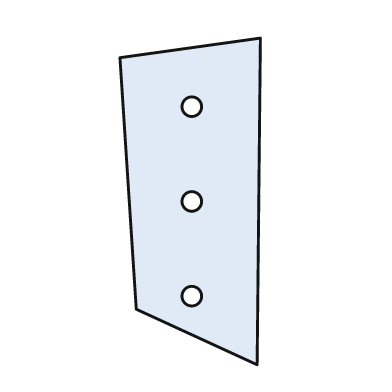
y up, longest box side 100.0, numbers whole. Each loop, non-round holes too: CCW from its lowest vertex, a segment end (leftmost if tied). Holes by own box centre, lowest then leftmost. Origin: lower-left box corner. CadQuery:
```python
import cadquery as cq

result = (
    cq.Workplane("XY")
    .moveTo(42.0, 0.0)
    .lineTo(43.0, 100.0)
    .lineTo(0.0, 94.0)
    .lineTo(5.0, 17.0)
    .close()
    .moveTo(22.0, 21.0)
    .circle(3.0)
    .moveTo(22.0, 50.0)
    .circle(3.0)
    .moveTo(22.0, 79.0)
    .circle(3.0)
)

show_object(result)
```